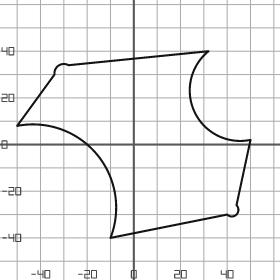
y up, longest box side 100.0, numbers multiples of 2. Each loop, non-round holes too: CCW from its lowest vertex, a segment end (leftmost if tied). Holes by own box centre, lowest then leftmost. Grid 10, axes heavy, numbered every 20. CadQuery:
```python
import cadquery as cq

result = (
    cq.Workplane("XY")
    .moveTo(-10.0, -40.0)
    .lineTo(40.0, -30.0)
    .threePointArc((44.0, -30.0), (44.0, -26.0))
    .lineTo(50.0, 2.0)
    .threePointArc((26.0, 14.0), (32.0, 40.0))
    .lineTo(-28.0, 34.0)
    .threePointArc((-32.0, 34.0), (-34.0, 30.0))
    .lineTo(-50.0, 8.0)
    .threePointArc((-16.0, -4.0), (-10.0, -40.0))
    .close()
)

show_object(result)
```